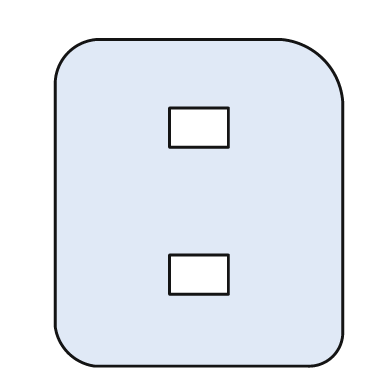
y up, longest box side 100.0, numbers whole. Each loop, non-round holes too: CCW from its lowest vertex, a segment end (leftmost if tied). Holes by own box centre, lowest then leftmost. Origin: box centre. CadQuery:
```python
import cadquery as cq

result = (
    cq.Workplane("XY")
    .moveTo(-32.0, -50.0)
    .lineTo(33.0, -50.0)
    .threePointArc((41.0, -47.0), (44.0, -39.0))
    .lineTo(44.0, 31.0)
    .threePointArc((38.0, 44.0), (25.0, 50.0))
    .lineTo(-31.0, 50.0)
    .threePointArc((-40.0, 46.0), (-44.0, 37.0))
    .lineTo(-44.0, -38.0)
    .threePointArc((-40.0, -46.0), (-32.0, -50.0))
    .close()
    .moveTo(-9.0, -28.0)
    .lineTo(9.0, -28.0)
    .lineTo(9.0, -16.0)
    .lineTo(-9.0, -16.0)
    .close()
    .moveTo(-9.0, 17.0)
    .lineTo(9.0, 17.0)
    .lineTo(9.0, 29.0)
    .lineTo(-9.0, 29.0)
    .close()
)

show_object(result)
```